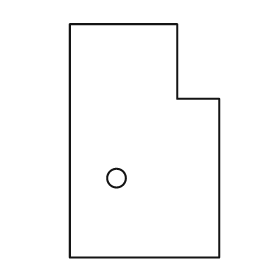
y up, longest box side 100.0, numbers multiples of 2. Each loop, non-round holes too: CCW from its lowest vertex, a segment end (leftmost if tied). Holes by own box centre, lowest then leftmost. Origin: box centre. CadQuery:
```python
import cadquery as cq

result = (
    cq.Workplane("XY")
    .moveTo(-32.0, -50.0)
    .lineTo(32.0, -50.0)
    .lineTo(32.0, 18.0)
    .lineTo(14.0, 18.0)
    .lineTo(14.0, 50.0)
    .lineTo(-32.0, 50.0)
    .close()
    .moveTo(-12.0, -16.0)
    .circle(4.0)
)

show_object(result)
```